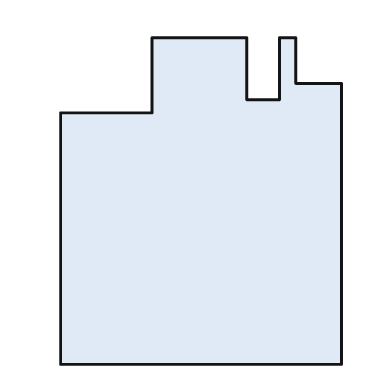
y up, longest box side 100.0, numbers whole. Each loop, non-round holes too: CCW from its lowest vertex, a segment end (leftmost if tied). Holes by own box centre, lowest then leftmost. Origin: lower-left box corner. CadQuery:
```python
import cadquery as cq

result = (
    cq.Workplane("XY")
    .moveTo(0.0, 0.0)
    .lineTo(86.0, 0.0)
    .lineTo(86.0, 86.0)
    .lineTo(72.0, 86.0)
    .lineTo(72.0, 100.0)
    .lineTo(67.0, 100.0)
    .lineTo(67.0, 81.0)
    .lineTo(57.0, 81.0)
    .lineTo(57.0, 100.0)
    .lineTo(28.0, 100.0)
    .lineTo(28.0, 77.0)
    .lineTo(0.0, 77.0)
    .close()
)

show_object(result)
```